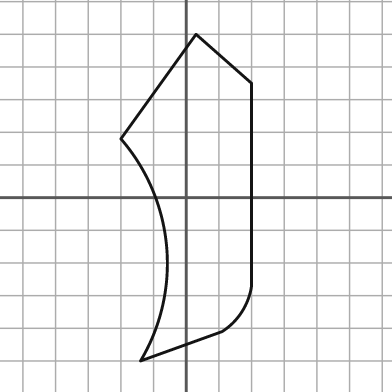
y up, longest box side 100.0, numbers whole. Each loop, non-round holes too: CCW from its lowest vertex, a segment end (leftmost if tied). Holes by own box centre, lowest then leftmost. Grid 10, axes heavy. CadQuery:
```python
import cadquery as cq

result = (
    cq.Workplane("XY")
    .moveTo(-14.0, -50.0)
    .lineTo(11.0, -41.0)
    .threePointArc((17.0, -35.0), (20.0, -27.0))
    .lineTo(20.0, 35.0)
    .lineTo(3.0, 50.0)
    .lineTo(-20.0, 18.0)
    .threePointArc((-6.0, -15.0), (-14.0, -50.0))
    .close()
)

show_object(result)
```